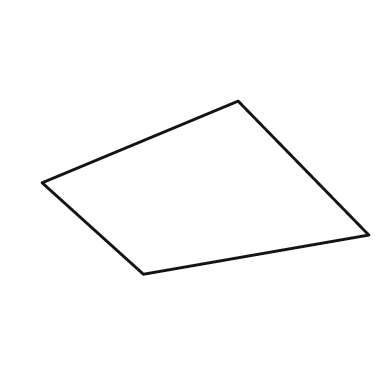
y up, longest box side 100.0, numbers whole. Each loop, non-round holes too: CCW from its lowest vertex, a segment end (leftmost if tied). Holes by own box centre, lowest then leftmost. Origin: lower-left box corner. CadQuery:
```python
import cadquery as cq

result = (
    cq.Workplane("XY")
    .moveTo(31.0, 0.0)
    .lineTo(100.0, 12.0)
    .lineTo(60.0, 53.0)
    .lineTo(0.0, 28.0)
    .close()
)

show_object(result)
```